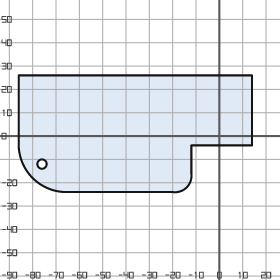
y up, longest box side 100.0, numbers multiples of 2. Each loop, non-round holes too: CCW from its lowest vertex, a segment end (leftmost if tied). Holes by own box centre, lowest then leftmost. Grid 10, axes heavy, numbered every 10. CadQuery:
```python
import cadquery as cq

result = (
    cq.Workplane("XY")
    .moveTo(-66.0, -24.0)
    .lineTo(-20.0, -24.0)
    .threePointArc((-14.0, -22.0), (-12.0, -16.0))
    .lineTo(-12.0, -4.0)
    .lineTo(14.0, -4.0)
    .lineTo(14.0, 26.0)
    .lineTo(-86.0, 26.0)
    .lineTo(-86.0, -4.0)
    .threePointArc((-80.0, -18.0), (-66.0, -24.0))
    .close()
    .moveTo(-76.0, -12.0)
    .circle(2.0)
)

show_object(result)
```